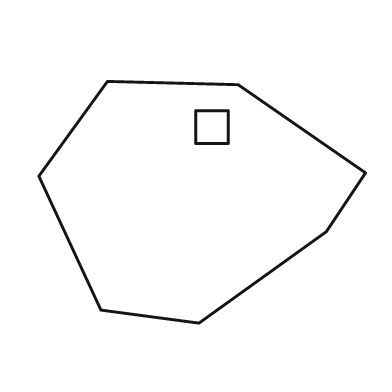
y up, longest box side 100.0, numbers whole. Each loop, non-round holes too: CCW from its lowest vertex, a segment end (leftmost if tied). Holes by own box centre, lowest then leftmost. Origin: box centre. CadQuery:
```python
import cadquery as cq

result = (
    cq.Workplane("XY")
    .moveTo(-1.0, -37.0)
    .lineTo(38.0, -9.0)
    .lineTo(50.0, 9.0)
    .lineTo(11.0, 36.0)
    .lineTo(-29.0, 37.0)
    .lineTo(-50.0, 8.0)
    .lineTo(-31.0, -33.0)
    .close()
    .moveTo(-2.0, 18.0)
    .lineTo(8.0, 18.0)
    .lineTo(8.0, 28.0)
    .lineTo(-2.0, 28.0)
    .close()
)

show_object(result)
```